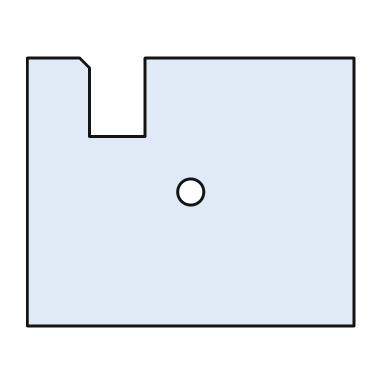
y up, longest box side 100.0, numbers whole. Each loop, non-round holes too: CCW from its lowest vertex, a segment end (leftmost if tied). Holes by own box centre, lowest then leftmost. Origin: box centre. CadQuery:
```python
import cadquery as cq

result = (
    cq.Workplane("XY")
    .moveTo(-50.0, -41.0)
    .lineTo(50.0, -41.0)
    .lineTo(50.0, 41.0)
    .lineTo(-14.0, 41.0)
    .lineTo(-14.0, 17.0)
    .lineTo(-31.0, 17.0)
    .lineTo(-31.0, 38.0)
    .lineTo(-34.0, 41.0)
    .lineTo(-50.0, 41.0)
    .close()
    .moveTo(0.0, 0.0)
    .circle(4.0)
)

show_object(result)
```